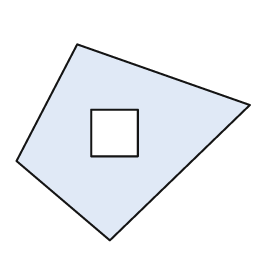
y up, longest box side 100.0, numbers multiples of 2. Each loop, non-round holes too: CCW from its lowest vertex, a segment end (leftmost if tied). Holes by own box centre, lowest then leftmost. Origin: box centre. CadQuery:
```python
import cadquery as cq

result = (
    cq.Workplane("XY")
    .moveTo(-10.0, -42.0)
    .lineTo(50.0, 16.0)
    .lineTo(-24.0, 42.0)
    .lineTo(-50.0, -8.0)
    .close()
    .moveTo(-18.0, -6.0)
    .lineTo(2.0, -6.0)
    .lineTo(2.0, 14.0)
    .lineTo(-18.0, 14.0)
    .close()
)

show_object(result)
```